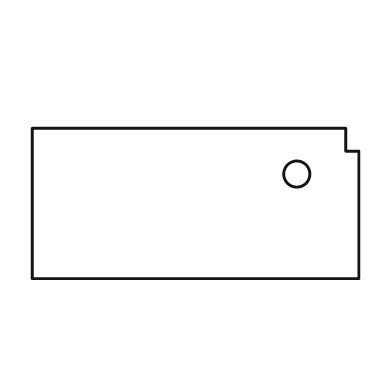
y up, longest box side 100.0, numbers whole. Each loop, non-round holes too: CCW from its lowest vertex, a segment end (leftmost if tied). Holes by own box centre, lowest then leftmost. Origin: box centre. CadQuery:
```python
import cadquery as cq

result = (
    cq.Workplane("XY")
    .moveTo(-50.0, -23.0)
    .lineTo(50.0, -23.0)
    .lineTo(50.0, 16.0)
    .lineTo(46.0, 16.0)
    .lineTo(46.0, 23.0)
    .lineTo(-50.0, 23.0)
    .close()
    .moveTo(31.0, 9.0)
    .circle(4.0)
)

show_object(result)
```